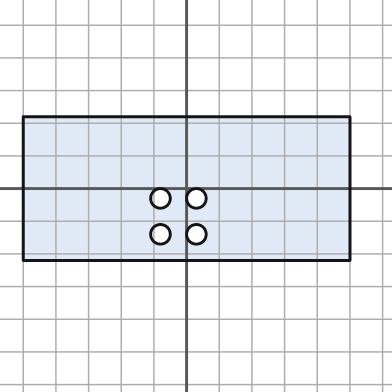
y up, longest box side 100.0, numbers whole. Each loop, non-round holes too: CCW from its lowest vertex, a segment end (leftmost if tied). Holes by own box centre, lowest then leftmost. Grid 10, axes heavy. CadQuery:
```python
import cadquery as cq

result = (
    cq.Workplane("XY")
    .moveTo(-50.0, -22.0)
    .lineTo(50.0, -22.0)
    .lineTo(50.0, 22.0)
    .lineTo(-50.0, 22.0)
    .close()
    .moveTo(-8.0, -14.0)
    .circle(3.0)
    .moveTo(3.0, -14.0)
    .circle(3.0)
    .moveTo(-8.0, -3.0)
    .circle(3.0)
    .moveTo(3.0, -3.0)
    .circle(3.0)
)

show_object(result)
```